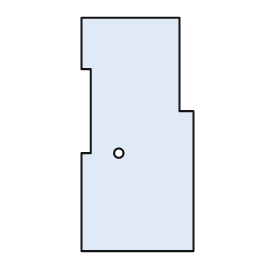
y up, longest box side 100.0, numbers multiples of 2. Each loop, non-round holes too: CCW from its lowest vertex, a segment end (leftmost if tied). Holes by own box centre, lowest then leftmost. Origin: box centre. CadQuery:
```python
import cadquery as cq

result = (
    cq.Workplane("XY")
    .moveTo(-24.0, -50.0)
    .lineTo(24.0, -50.0)
    .lineTo(24.0, 10.0)
    .lineTo(18.0, 10.0)
    .lineTo(18.0, 50.0)
    .lineTo(-24.0, 50.0)
    .lineTo(-24.0, 28.0)
    .lineTo(-20.0, 28.0)
    .lineTo(-20.0, -8.0)
    .lineTo(-24.0, -8.0)
    .close()
    .moveTo(-8.0, -8.0)
    .circle(2.0)
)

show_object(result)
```